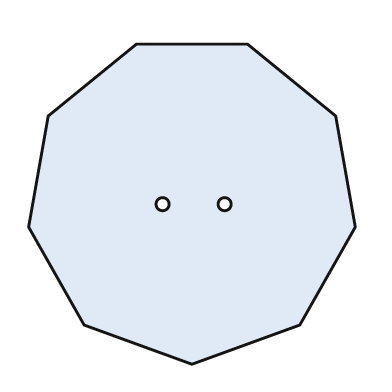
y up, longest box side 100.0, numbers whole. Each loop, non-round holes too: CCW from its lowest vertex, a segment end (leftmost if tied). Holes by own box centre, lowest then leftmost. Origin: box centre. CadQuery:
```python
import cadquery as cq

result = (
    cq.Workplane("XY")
    .moveTo(0.0, -49.0)
    .lineTo(33.0, -37.0)
    .lineTo(50.0, -7.0)
    .lineTo(44.0, 27.0)
    .lineTo(17.0, 49.0)
    .lineTo(-17.0, 49.0)
    .lineTo(-44.0, 27.0)
    .lineTo(-50.0, -7.0)
    .lineTo(-33.0, -37.0)
    .close()
    .moveTo(-9.0, 0.0)
    .circle(2.0)
    .moveTo(10.0, 0.0)
    .circle(2.0)
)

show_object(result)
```